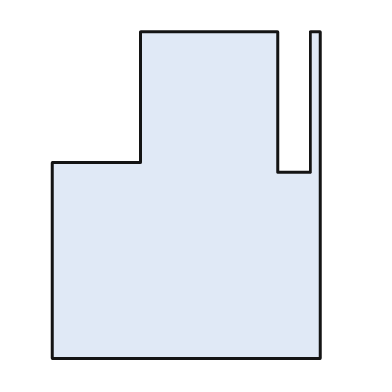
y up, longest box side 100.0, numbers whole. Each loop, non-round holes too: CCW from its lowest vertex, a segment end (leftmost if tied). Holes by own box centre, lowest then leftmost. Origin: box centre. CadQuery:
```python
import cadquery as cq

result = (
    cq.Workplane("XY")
    .moveTo(-41.0, -50.0)
    .lineTo(41.0, -50.0)
    .lineTo(41.0, 50.0)
    .lineTo(38.0, 50.0)
    .lineTo(38.0, 7.0)
    .lineTo(28.0, 7.0)
    .lineTo(28.0, 50.0)
    .lineTo(-14.0, 50.0)
    .lineTo(-14.0, 10.0)
    .lineTo(-41.0, 10.0)
    .close()
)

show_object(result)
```